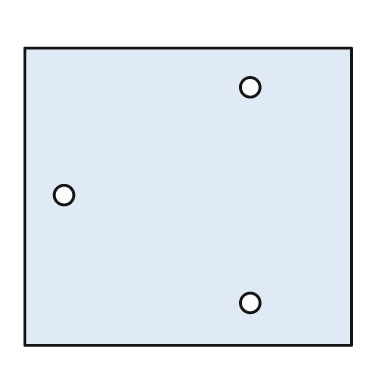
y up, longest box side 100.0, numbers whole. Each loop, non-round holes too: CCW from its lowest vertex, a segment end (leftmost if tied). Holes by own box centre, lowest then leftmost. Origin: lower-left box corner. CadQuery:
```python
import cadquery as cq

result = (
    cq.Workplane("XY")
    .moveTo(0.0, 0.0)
    .lineTo(100.0, 0.0)
    .lineTo(100.0, 91.0)
    .lineTo(0.0, 91.0)
    .close()
    .moveTo(69.0, 13.0)
    .circle(3.0)
    .moveTo(12.0, 46.0)
    .circle(3.0)
    .moveTo(69.0, 79.0)
    .circle(3.0)
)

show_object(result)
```